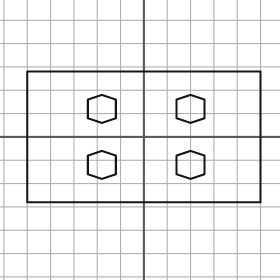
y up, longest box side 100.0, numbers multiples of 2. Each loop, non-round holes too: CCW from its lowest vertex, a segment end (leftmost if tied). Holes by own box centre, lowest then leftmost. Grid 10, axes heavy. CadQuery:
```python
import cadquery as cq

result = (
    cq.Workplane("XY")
    .moveTo(-50.0, -28.0)
    .lineTo(50.0, -28.0)
    .lineTo(50.0, 28.0)
    .lineTo(-50.0, 28.0)
    .close()
    .moveTo(-18.0, -18.0)
    .lineTo(-12.0, -16.0)
    .lineTo(-12.0, -8.0)
    .lineTo(-18.0, -6.0)
    .lineTo(-24.0, -8.0)
    .lineTo(-24.0, -16.0)
    .close()
    .moveTo(20.0, -18.0)
    .lineTo(26.0, -16.0)
    .lineTo(26.0, -8.0)
    .lineTo(20.0, -6.0)
    .lineTo(14.0, -8.0)
    .lineTo(14.0, -16.0)
    .close()
    .moveTo(-18.0, 6.0)
    .lineTo(-12.0, 8.0)
    .lineTo(-12.0, 16.0)
    .lineTo(-18.0, 18.0)
    .lineTo(-24.0, 16.0)
    .lineTo(-24.0, 8.0)
    .close()
    .moveTo(20.0, 6.0)
    .lineTo(26.0, 8.0)
    .lineTo(26.0, 16.0)
    .lineTo(20.0, 18.0)
    .lineTo(14.0, 16.0)
    .lineTo(14.0, 8.0)
    .close()
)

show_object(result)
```